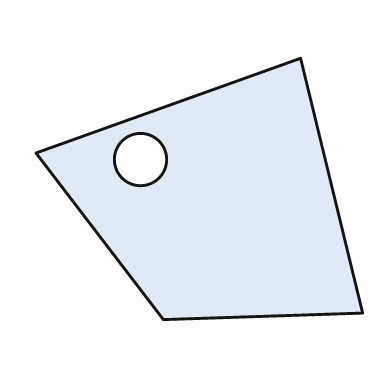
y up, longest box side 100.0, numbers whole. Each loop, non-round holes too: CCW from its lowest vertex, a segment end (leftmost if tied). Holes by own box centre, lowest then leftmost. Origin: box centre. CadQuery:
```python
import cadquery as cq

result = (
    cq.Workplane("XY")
    .moveTo(-11.0, -40.0)
    .lineTo(50.0, -38.0)
    .lineTo(31.0, 40.0)
    .lineTo(-50.0, 11.0)
    .close()
    .moveTo(-18.0, 9.0)
    .circle(8.0)
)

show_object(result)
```